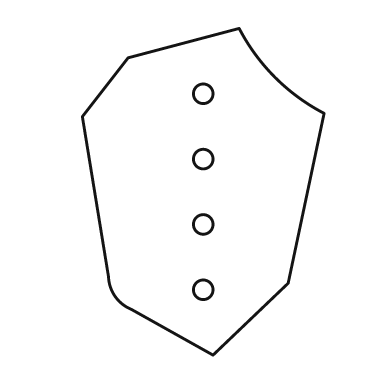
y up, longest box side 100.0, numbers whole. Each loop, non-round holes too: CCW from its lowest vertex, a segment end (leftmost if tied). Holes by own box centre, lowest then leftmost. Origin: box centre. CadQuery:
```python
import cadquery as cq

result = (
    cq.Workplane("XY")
    .moveTo(3.0, -50.0)
    .lineTo(26.0, -28.0)
    .lineTo(37.0, 24.0)
    .threePointArc((22.0, 35.0), (11.0, 50.0))
    .lineTo(-23.0, 41.0)
    .lineTo(-37.0, 23.0)
    .lineTo(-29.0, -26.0)
    .threePointArc((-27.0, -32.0), (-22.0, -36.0))
    .close()
    .moveTo(0.0, -30.0)
    .circle(3.0)
    .moveTo(0.0, -10.0)
    .circle(3.0)
    .moveTo(0.0, 10.0)
    .circle(3.0)
    .moveTo(0.0, 30.0)
    .circle(3.0)
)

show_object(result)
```